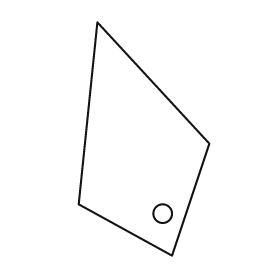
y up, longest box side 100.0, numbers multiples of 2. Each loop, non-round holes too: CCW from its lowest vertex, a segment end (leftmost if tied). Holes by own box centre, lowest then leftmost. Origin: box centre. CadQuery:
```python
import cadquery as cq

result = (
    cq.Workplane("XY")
    .moveTo(12.0, -50.0)
    .lineTo(28.0, -2.0)
    .lineTo(-20.0, 50.0)
    .lineTo(-28.0, -28.0)
    .close()
    .moveTo(8.0, -32.0)
    .circle(4.0)
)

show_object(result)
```